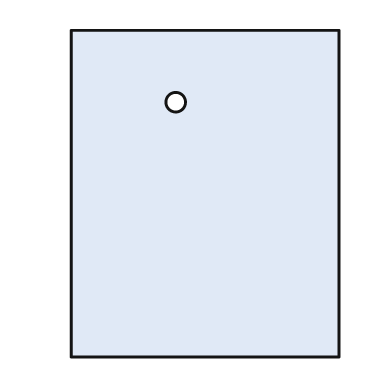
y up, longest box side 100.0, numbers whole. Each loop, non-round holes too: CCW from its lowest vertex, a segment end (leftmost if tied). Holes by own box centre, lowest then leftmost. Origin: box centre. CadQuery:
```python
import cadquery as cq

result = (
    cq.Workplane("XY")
    .moveTo(-41.0, -50.0)
    .lineTo(41.0, -50.0)
    .lineTo(41.0, 50.0)
    .lineTo(-41.0, 50.0)
    .close()
    .moveTo(-9.0, 28.0)
    .circle(3.0)
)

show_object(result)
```